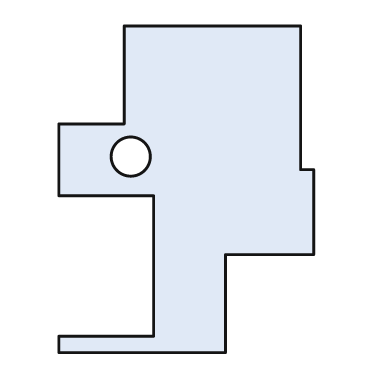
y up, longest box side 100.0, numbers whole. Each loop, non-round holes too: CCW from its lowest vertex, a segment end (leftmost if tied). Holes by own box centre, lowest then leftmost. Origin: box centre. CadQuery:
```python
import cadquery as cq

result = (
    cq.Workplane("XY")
    .moveTo(-39.0, -50.0)
    .lineTo(12.0, -50.0)
    .lineTo(12.0, -20.0)
    .lineTo(39.0, -20.0)
    .lineTo(39.0, 6.0)
    .lineTo(35.0, 6.0)
    .lineTo(35.0, 50.0)
    .lineTo(-19.0, 50.0)
    .lineTo(-19.0, 20.0)
    .lineTo(-39.0, 20.0)
    .lineTo(-39.0, -2.0)
    .lineTo(-10.0, -2.0)
    .lineTo(-10.0, -45.0)
    .lineTo(-39.0, -45.0)
    .close()
    .moveTo(-17.0, 10.0)
    .circle(6.0)
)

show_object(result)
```